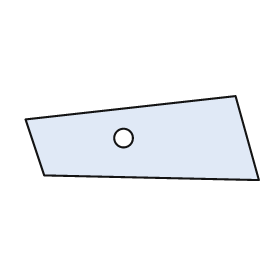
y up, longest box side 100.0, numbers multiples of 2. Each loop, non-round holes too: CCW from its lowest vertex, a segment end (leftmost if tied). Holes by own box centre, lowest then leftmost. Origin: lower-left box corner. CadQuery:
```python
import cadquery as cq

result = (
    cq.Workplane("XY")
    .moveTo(100.0, 0.0)
    .lineTo(90.0, 36.0)
    .lineTo(0.0, 26.0)
    .lineTo(8.0, 2.0)
    .close()
    .moveTo(42.0, 18.0)
    .circle(4.0)
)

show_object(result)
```